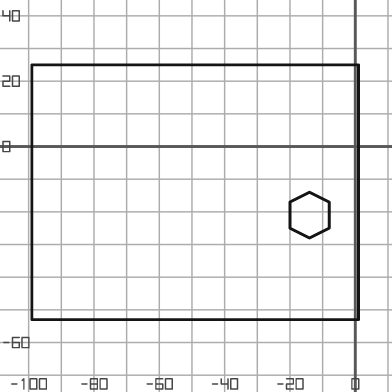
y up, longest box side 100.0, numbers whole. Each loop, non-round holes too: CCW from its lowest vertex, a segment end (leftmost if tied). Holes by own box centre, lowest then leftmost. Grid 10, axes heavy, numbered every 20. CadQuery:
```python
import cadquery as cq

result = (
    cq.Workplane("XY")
    .moveTo(-99.0, -53.0)
    .lineTo(1.0, -53.0)
    .lineTo(1.0, 25.0)
    .lineTo(-99.0, 25.0)
    .close()
    .moveTo(-14.0, -28.0)
    .lineTo(-8.0, -25.0)
    .lineTo(-8.0, -17.0)
    .lineTo(-14.0, -14.0)
    .lineTo(-20.0, -17.0)
    .lineTo(-20.0, -25.0)
    .close()
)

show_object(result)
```